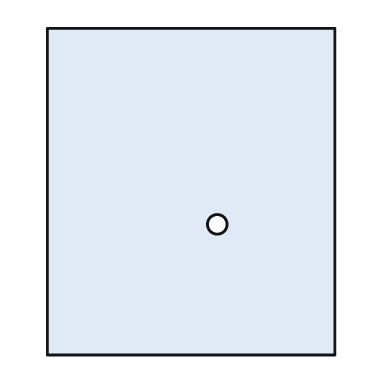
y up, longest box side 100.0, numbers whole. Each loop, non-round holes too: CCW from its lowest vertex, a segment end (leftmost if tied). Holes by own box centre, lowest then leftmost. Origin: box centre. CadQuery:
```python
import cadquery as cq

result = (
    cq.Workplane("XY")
    .moveTo(-44.0, -50.0)
    .lineTo(44.0, -50.0)
    .lineTo(44.0, 50.0)
    .lineTo(-44.0, 50.0)
    .close()
    .moveTo(8.0, -10.0)
    .circle(3.0)
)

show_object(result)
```